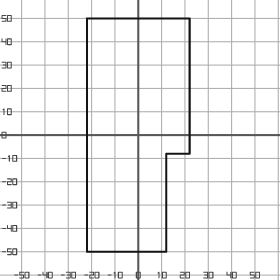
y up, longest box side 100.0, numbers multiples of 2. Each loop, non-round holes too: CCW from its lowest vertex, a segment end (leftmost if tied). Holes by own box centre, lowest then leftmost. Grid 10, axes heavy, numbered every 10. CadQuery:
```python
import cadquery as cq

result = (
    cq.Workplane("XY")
    .moveTo(-22.0, -50.0)
    .lineTo(12.0, -50.0)
    .lineTo(12.0, -8.0)
    .lineTo(22.0, -8.0)
    .lineTo(22.0, 50.0)
    .lineTo(-22.0, 50.0)
    .close()
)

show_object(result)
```